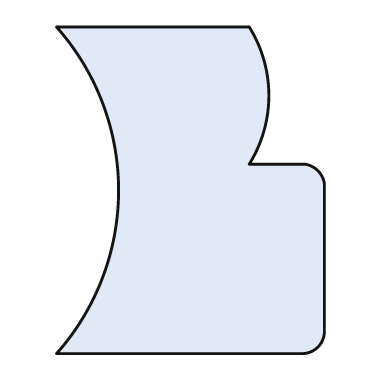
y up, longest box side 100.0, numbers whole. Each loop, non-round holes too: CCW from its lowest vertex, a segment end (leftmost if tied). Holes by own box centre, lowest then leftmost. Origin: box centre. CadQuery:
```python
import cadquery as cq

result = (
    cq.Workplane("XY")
    .moveTo(-41.0, -50.0)
    .lineTo(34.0, -50.0)
    .threePointArc((39.0, -48.0), (41.0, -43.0))
    .lineTo(41.0, 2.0)
    .threePointArc((39.0, 6.0), (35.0, 8.0))
    .lineTo(18.0, 8.0)
    .threePointArc((24.0, 29.0), (18.0, 50.0))
    .lineTo(-41.0, 50.0)
    .threePointArc((-22.0, 0.0), (-41.0, -50.0))
    .close()
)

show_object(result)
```